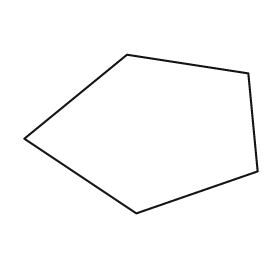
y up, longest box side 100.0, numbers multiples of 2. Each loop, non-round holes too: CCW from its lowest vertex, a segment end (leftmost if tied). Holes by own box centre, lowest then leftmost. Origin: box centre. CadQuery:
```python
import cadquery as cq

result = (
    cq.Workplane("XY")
    .moveTo(-2.0, -34.0)
    .lineTo(50.0, -16.0)
    .lineTo(46.0, 26.0)
    .lineTo(-6.0, 34.0)
    .lineTo(-50.0, -2.0)
    .close()
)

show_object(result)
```